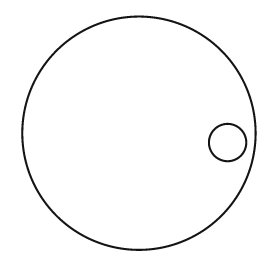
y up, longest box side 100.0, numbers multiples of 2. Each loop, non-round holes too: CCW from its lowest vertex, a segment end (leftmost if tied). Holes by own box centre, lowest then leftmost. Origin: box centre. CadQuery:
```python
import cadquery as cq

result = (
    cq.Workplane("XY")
    .moveTo(0.0, 0.0)
    .circle(50.0)
    .moveTo(38.0, -4.0)
    .circle(8.0)
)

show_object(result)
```